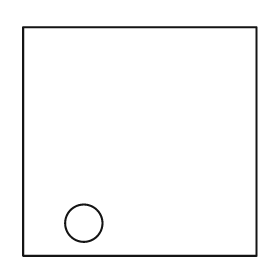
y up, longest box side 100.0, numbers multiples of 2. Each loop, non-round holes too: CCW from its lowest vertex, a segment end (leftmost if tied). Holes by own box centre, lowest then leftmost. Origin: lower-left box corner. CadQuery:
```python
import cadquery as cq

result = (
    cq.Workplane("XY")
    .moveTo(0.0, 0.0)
    .lineTo(100.0, 0.0)
    .lineTo(100.0, 98.0)
    .lineTo(0.0, 98.0)
    .close()
    .moveTo(26.0, 14.0)
    .circle(8.0)
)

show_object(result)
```